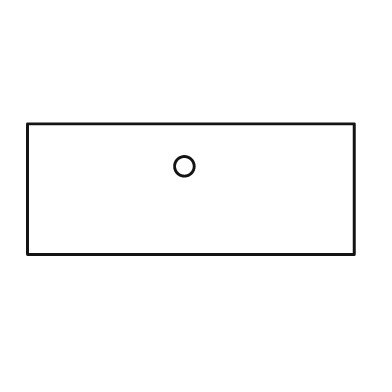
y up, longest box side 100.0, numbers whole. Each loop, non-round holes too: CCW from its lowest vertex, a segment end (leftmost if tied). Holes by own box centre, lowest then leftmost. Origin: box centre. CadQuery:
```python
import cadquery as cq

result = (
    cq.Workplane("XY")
    .moveTo(-50.0, -20.0)
    .lineTo(50.0, -20.0)
    .lineTo(50.0, 20.0)
    .lineTo(-50.0, 20.0)
    .close()
    .moveTo(-2.0, 7.0)
    .circle(3.0)
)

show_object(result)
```